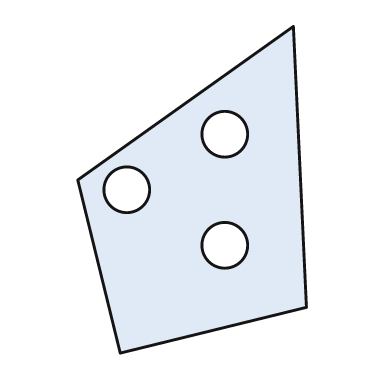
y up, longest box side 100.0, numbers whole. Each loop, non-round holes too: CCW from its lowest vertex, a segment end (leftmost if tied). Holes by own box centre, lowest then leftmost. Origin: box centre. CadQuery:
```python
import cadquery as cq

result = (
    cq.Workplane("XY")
    .moveTo(-22.0, -50.0)
    .lineTo(35.0, -36.0)
    .lineTo(31.0, 50.0)
    .lineTo(-35.0, 3.0)
    .close()
    .moveTo(10.0, -17.0)
    .circle(7.0)
    .moveTo(-20.0, 0.0)
    .circle(7.0)
    .moveTo(10.0, 17.0)
    .circle(7.0)
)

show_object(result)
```